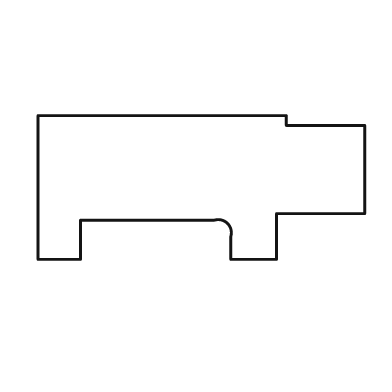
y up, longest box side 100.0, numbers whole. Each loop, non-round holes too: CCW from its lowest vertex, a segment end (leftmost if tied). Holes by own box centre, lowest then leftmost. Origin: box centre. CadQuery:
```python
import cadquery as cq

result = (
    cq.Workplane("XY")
    .moveTo(-50.0, -22.0)
    .lineTo(-37.0, -22.0)
    .lineTo(-37.0, -10.0)
    .lineTo(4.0, -10.0)
    .threePointArc((8.0, -11.0), (9.0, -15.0))
    .lineTo(9.0, -22.0)
    .lineTo(23.0, -22.0)
    .lineTo(23.0, -8.0)
    .lineTo(50.0, -8.0)
    .lineTo(50.0, 19.0)
    .lineTo(26.0, 19.0)
    .lineTo(26.0, 22.0)
    .lineTo(-50.0, 22.0)
    .close()
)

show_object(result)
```